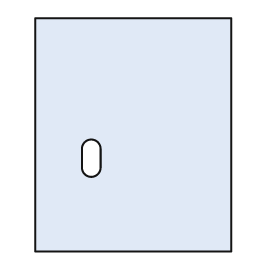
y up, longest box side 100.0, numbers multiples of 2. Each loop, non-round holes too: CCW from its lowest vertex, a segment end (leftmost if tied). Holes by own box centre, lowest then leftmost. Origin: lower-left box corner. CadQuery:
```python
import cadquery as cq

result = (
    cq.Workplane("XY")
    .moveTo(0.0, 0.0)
    .lineTo(84.0, 0.0)
    .lineTo(84.0, 100.0)
    .lineTo(0.0, 100.0)
    .close()
    .moveTo(20.0, 36.0)
    .threePointArc((24.0, 32.0), (28.0, 36.0))
    .lineTo(28.0, 44.0)
    .threePointArc((24.0, 48.0), (20.0, 44.0))
    .close()
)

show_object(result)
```